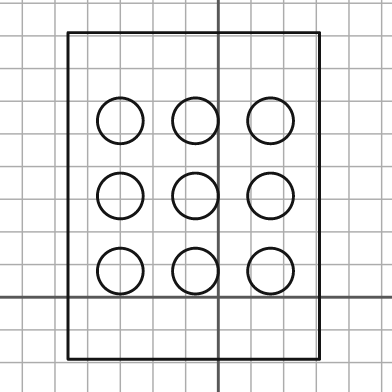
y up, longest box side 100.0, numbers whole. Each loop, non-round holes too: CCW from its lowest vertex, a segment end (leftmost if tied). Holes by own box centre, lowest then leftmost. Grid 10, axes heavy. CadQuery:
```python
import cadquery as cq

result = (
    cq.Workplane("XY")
    .moveTo(-46.0, -19.0)
    .lineTo(31.0, -19.0)
    .lineTo(31.0, 81.0)
    .lineTo(-46.0, 81.0)
    .close()
    .moveTo(-30.0, 8.0)
    .circle(7.0)
    .moveTo(-7.0, 8.0)
    .circle(7.0)
    .moveTo(16.0, 8.0)
    .circle(7.0)
    .moveTo(-30.0, 31.0)
    .circle(7.0)
    .moveTo(-7.0, 31.0)
    .circle(7.0)
    .moveTo(16.0, 31.0)
    .circle(7.0)
    .moveTo(-30.0, 54.0)
    .circle(7.0)
    .moveTo(-7.0, 54.0)
    .circle(7.0)
    .moveTo(16.0, 54.0)
    .circle(7.0)
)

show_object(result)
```